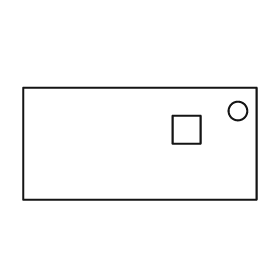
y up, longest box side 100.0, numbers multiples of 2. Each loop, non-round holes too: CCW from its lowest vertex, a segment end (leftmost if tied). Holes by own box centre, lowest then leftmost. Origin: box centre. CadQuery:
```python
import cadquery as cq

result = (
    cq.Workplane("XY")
    .moveTo(-50.0, -24.0)
    .lineTo(50.0, -24.0)
    .lineTo(50.0, 24.0)
    .lineTo(-50.0, 24.0)
    .close()
    .moveTo(14.0, 0.0)
    .lineTo(26.0, 0.0)
    .lineTo(26.0, 12.0)
    .lineTo(14.0, 12.0)
    .close()
    .moveTo(42.0, 14.0)
    .circle(4.0)
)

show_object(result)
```